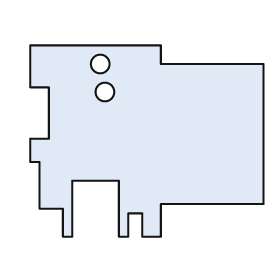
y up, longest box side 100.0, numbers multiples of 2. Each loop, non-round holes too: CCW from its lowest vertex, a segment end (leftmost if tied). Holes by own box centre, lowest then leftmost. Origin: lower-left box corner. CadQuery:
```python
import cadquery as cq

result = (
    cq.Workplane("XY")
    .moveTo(14.0, 0.0)
    .lineTo(18.0, 0.0)
    .lineTo(18.0, 24.0)
    .lineTo(38.0, 24.0)
    .lineTo(38.0, 0.0)
    .lineTo(42.0, 0.0)
    .lineTo(42.0, 10.0)
    .lineTo(48.0, 10.0)
    .lineTo(48.0, 0.0)
    .lineTo(56.0, 0.0)
    .lineTo(56.0, 14.0)
    .lineTo(100.0, 14.0)
    .lineTo(100.0, 74.0)
    .lineTo(56.0, 74.0)
    .lineTo(56.0, 82.0)
    .lineTo(0.0, 82.0)
    .lineTo(0.0, 64.0)
    .lineTo(8.0, 64.0)
    .lineTo(8.0, 42.0)
    .lineTo(0.0, 42.0)
    .lineTo(0.0, 32.0)
    .lineTo(4.0, 32.0)
    .lineTo(4.0, 12.0)
    .lineTo(14.0, 12.0)
    .close()
    .moveTo(32.0, 62.0)
    .circle(4.0)
    .moveTo(30.0, 74.0)
    .circle(4.0)
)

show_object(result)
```